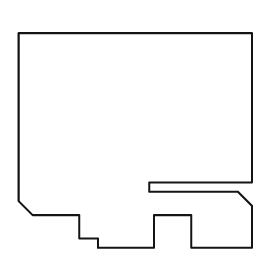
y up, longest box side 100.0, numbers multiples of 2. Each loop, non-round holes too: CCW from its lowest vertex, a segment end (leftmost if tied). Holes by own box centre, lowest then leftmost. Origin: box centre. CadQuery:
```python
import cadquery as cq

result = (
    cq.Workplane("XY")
    .moveTo(-16.0, -46.0)
    .lineTo(8.0, -46.0)
    .lineTo(8.0, -32.0)
    .lineTo(24.0, -32.0)
    .lineTo(24.0, -46.0)
    .lineTo(50.0, -46.0)
    .lineTo(50.0, -28.0)
    .lineTo(44.0, -22.0)
    .lineTo(6.0, -22.0)
    .lineTo(6.0, -18.0)
    .lineTo(50.0, -18.0)
    .lineTo(50.0, 46.0)
    .lineTo(-50.0, 46.0)
    .lineTo(-50.0, -26.0)
    .lineTo(-44.0, -32.0)
    .lineTo(-24.0, -32.0)
    .lineTo(-24.0, -42.0)
    .lineTo(-16.0, -42.0)
    .close()
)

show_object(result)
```